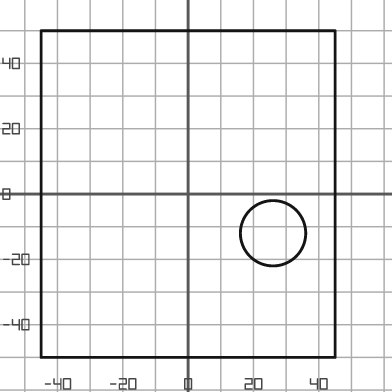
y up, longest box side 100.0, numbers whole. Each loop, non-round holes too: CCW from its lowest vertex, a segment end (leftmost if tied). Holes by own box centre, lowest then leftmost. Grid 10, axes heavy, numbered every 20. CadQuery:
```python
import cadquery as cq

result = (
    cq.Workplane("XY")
    .moveTo(-45.0, -50.0)
    .lineTo(45.0, -50.0)
    .lineTo(45.0, 50.0)
    .lineTo(-45.0, 50.0)
    .close()
    .moveTo(26.0, -12.0)
    .circle(10.0)
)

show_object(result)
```